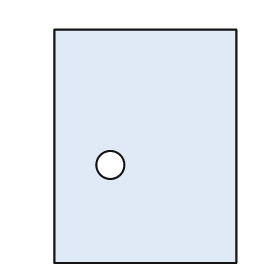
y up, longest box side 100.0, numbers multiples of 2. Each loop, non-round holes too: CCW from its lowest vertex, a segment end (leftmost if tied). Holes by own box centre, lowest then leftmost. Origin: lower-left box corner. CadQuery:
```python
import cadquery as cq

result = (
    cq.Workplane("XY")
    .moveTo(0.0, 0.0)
    .lineTo(78.0, 0.0)
    .lineTo(78.0, 100.0)
    .lineTo(0.0, 100.0)
    .close()
    .moveTo(24.0, 42.0)
    .circle(6.0)
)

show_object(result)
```